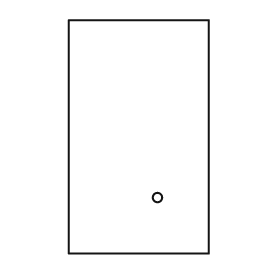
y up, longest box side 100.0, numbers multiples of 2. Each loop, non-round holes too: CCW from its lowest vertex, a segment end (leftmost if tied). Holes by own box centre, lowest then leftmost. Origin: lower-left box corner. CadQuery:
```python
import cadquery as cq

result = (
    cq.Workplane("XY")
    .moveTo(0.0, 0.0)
    .lineTo(60.0, 0.0)
    .lineTo(60.0, 100.0)
    .lineTo(0.0, 100.0)
    .close()
    .moveTo(38.0, 24.0)
    .circle(2.0)
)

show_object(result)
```